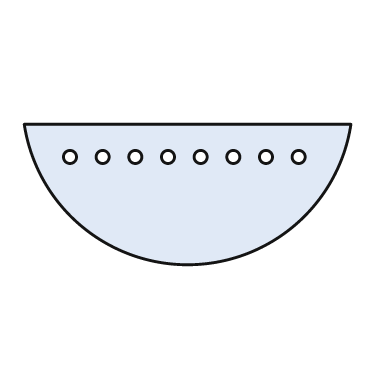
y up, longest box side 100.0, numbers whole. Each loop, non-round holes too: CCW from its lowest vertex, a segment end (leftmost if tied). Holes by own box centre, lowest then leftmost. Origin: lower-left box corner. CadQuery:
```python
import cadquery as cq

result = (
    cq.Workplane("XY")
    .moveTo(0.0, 43.0)
    .threePointArc((50.0, 0.0), (100.0, 43.0))
    .close()
    .moveTo(14.0, 33.0)
    .circle(2.0)
    .moveTo(24.0, 33.0)
    .circle(2.0)
    .moveTo(34.0, 33.0)
    .circle(2.0)
    .moveTo(44.0, 33.0)
    .circle(2.0)
    .moveTo(54.0, 33.0)
    .circle(2.0)
    .moveTo(64.0, 33.0)
    .circle(2.0)
    .moveTo(74.0, 33.0)
    .circle(2.0)
    .moveTo(84.0, 33.0)
    .circle(2.0)
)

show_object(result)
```